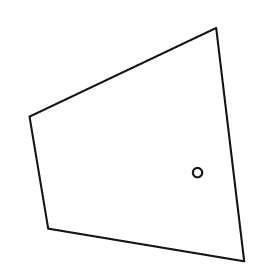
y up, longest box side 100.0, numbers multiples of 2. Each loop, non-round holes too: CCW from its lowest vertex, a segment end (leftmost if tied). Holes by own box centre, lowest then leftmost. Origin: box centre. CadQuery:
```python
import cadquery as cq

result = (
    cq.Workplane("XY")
    .moveTo(46.0, -50.0)
    .lineTo(34.0, 50.0)
    .lineTo(-46.0, 12.0)
    .lineTo(-38.0, -36.0)
    .close()
    .moveTo(26.0, -12.0)
    .circle(2.0)
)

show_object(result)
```